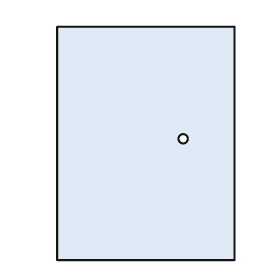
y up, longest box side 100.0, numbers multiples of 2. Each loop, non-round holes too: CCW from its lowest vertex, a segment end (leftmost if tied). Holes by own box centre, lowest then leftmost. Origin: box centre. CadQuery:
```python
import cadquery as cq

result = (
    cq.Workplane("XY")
    .moveTo(-38.0, -50.0)
    .lineTo(38.0, -50.0)
    .lineTo(38.0, 50.0)
    .lineTo(-38.0, 50.0)
    .close()
    .moveTo(16.0, 2.0)
    .circle(2.0)
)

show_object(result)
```